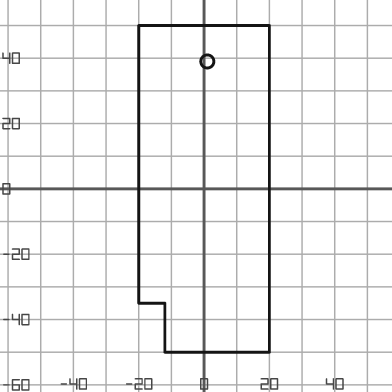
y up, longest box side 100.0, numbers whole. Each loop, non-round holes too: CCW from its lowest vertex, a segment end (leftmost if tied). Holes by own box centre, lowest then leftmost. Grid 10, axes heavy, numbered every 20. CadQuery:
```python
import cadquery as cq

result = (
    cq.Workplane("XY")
    .moveTo(-12.0, -50.0)
    .lineTo(20.0, -50.0)
    .lineTo(20.0, 50.0)
    .lineTo(-20.0, 50.0)
    .lineTo(-20.0, -35.0)
    .lineTo(-12.0, -35.0)
    .close()
    .moveTo(1.0, 39.0)
    .circle(2.0)
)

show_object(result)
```